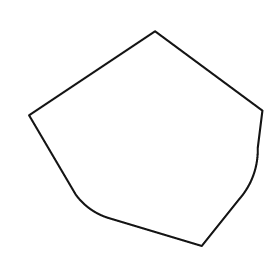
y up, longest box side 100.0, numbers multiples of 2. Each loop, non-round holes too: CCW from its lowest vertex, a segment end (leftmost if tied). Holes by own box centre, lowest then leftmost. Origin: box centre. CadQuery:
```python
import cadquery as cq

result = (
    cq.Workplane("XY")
    .moveTo(24.0, -46.0)
    .lineTo(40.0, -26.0)
    .threePointArc((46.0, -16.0), (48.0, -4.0))
    .lineTo(50.0, 12.0)
    .lineTo(4.0, 46.0)
    .lineTo(-50.0, 10.0)
    .lineTo(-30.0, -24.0)
    .threePointArc((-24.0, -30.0), (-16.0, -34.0))
    .close()
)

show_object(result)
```